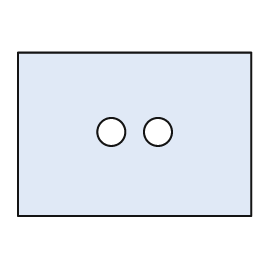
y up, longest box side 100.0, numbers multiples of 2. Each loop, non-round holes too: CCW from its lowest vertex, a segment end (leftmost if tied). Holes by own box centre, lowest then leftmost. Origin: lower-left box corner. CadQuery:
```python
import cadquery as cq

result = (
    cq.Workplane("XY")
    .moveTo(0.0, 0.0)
    .lineTo(100.0, 0.0)
    .lineTo(100.0, 70.0)
    .lineTo(0.0, 70.0)
    .close()
    .moveTo(40.0, 36.0)
    .circle(6.0)
    .moveTo(60.0, 36.0)
    .circle(6.0)
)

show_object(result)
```